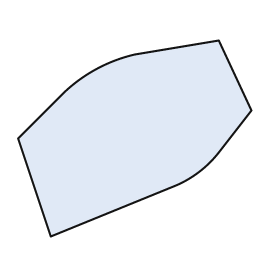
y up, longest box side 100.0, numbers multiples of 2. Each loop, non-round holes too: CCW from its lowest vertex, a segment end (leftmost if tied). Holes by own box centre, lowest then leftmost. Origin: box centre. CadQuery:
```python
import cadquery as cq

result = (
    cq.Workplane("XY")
    .moveTo(-36.0, -42.0)
    .lineTo(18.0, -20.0)
    .threePointArc((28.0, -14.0), (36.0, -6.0))
    .lineTo(50.0, 12.0)
    .lineTo(36.0, 42.0)
    .lineTo(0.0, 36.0)
    .threePointArc((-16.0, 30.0), (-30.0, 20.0))
    .lineTo(-50.0, 0.0)
    .close()
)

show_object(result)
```